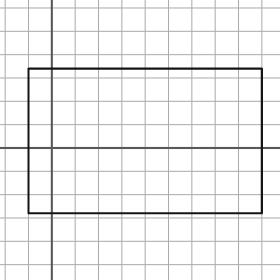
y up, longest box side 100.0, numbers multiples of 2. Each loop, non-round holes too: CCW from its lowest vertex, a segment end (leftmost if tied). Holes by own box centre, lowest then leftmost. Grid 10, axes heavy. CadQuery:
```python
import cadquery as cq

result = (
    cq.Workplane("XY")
    .moveTo(-10.0, -28.0)
    .lineTo(90.0, -28.0)
    .lineTo(90.0, 34.0)
    .lineTo(-10.0, 34.0)
    .close()
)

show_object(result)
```